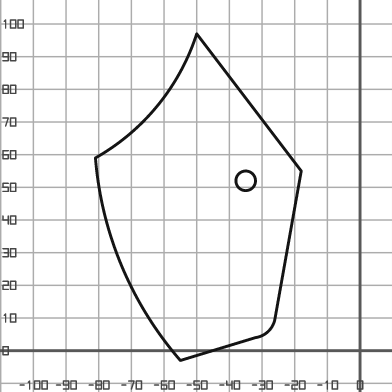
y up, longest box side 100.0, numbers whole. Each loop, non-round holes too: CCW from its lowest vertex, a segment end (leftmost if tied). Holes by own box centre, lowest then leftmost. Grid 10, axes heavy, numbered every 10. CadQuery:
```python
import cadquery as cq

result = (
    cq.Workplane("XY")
    .moveTo(-55.0, -3.0)
    .lineTo(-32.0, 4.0)
    .threePointArc((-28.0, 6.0), (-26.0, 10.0))
    .lineTo(-18.0, 55.0)
    .lineTo(-50.0, 97.0)
    .threePointArc((-62.0, 75.0), (-81.0, 59.0))
    .threePointArc((-73.0, 26.0), (-55.0, -3.0))
    .close()
    .moveTo(-35.0, 52.0)
    .circle(3.0)
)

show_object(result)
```